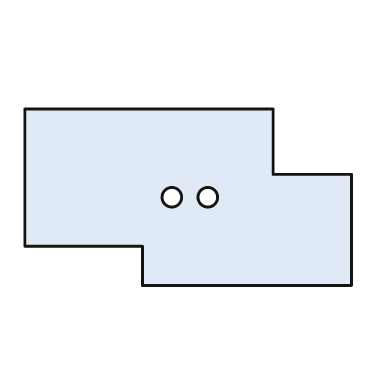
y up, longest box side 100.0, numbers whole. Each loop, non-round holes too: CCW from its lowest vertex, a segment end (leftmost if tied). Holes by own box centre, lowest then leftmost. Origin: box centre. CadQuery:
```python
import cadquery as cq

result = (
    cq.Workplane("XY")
    .moveTo(-14.0, -27.0)
    .lineTo(50.0, -27.0)
    .lineTo(50.0, 7.0)
    .lineTo(26.0, 7.0)
    .lineTo(26.0, 27.0)
    .lineTo(-50.0, 27.0)
    .lineTo(-50.0, -15.0)
    .lineTo(-14.0, -15.0)
    .close()
    .moveTo(-5.0, 0.0)
    .circle(3.0)
    .moveTo(6.0, 0.0)
    .circle(3.0)
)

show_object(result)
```